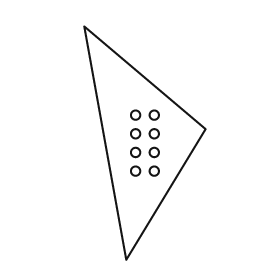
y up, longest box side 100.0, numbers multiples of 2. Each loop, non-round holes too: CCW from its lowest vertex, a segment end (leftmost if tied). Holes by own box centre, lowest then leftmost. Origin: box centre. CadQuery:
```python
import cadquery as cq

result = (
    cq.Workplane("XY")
    .moveTo(-8.0, -50.0)
    .lineTo(26.0, 6.0)
    .lineTo(-26.0, 50.0)
    .close()
    .moveTo(-4.0, -12.0)
    .circle(2.0)
    .moveTo(4.0, -12.0)
    .circle(2.0)
    .moveTo(-4.0, -4.0)
    .circle(2.0)
    .moveTo(4.0, -4.0)
    .circle(2.0)
    .moveTo(-4.0, 4.0)
    .circle(2.0)
    .moveTo(4.0, 4.0)
    .circle(2.0)
    .moveTo(-4.0, 12.0)
    .circle(2.0)
    .moveTo(4.0, 12.0)
    .circle(2.0)
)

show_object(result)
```